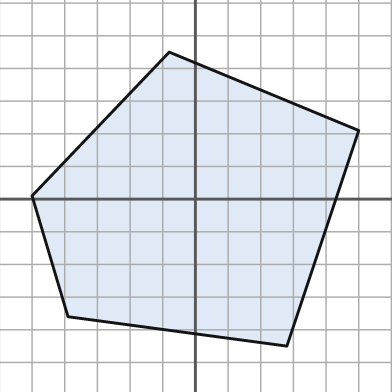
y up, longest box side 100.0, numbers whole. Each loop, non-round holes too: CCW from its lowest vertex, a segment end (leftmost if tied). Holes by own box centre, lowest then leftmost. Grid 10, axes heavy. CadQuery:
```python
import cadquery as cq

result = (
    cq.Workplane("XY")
    .moveTo(28.0, -45.0)
    .lineTo(50.0, 21.0)
    .lineTo(-8.0, 45.0)
    .lineTo(-50.0, 1.0)
    .lineTo(-39.0, -36.0)
    .close()
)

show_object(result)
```